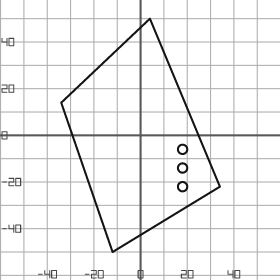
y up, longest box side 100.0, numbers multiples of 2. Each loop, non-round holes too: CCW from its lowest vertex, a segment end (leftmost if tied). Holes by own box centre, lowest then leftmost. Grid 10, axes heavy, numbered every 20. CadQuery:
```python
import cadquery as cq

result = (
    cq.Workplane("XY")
    .moveTo(-12.0, -50.0)
    .lineTo(34.0, -22.0)
    .lineTo(4.0, 50.0)
    .lineTo(-34.0, 14.0)
    .close()
    .moveTo(18.0, -22.0)
    .circle(2.0)
    .moveTo(18.0, -14.0)
    .circle(2.0)
    .moveTo(18.0, -6.0)
    .circle(2.0)
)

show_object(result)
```